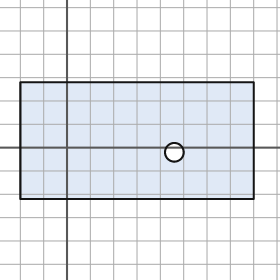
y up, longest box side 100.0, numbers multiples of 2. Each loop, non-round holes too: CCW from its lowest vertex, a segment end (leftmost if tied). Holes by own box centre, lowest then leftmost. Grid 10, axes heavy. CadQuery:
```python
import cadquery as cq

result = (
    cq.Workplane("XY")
    .moveTo(-20.0, -22.0)
    .lineTo(80.0, -22.0)
    .lineTo(80.0, 28.0)
    .lineTo(-20.0, 28.0)
    .close()
    .moveTo(46.0, -2.0)
    .circle(4.0)
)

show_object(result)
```